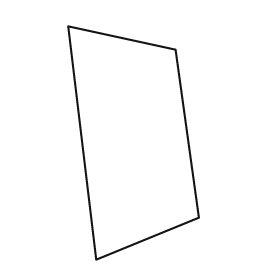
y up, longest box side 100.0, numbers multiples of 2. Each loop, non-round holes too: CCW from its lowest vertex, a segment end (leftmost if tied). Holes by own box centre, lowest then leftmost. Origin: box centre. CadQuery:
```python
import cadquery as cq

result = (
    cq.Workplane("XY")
    .moveTo(-16.0, -50.0)
    .lineTo(28.0, -32.0)
    .lineTo(18.0, 40.0)
    .lineTo(-28.0, 50.0)
    .close()
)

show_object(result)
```